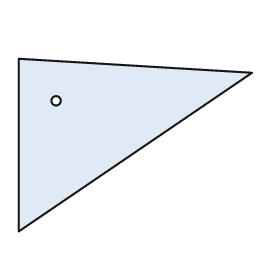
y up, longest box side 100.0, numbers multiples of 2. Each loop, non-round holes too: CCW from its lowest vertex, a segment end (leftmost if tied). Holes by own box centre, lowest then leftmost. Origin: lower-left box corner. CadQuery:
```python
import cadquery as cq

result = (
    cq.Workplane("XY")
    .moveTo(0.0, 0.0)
    .lineTo(100.0, 68.0)
    .lineTo(0.0, 74.0)
    .close()
    .moveTo(16.0, 56.0)
    .circle(2.0)
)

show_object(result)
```